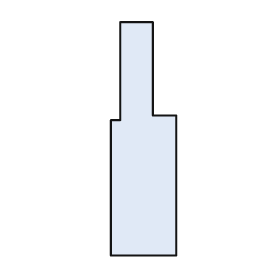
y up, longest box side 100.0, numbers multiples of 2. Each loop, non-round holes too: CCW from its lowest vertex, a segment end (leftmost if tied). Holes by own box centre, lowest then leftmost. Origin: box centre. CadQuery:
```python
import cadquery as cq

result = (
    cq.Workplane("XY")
    .moveTo(-14.0, -50.0)
    .lineTo(14.0, -50.0)
    .lineTo(14.0, 10.0)
    .lineTo(4.0, 10.0)
    .lineTo(4.0, 50.0)
    .lineTo(-10.0, 50.0)
    .lineTo(-10.0, 8.0)
    .lineTo(-14.0, 8.0)
    .close()
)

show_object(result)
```